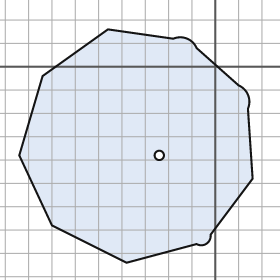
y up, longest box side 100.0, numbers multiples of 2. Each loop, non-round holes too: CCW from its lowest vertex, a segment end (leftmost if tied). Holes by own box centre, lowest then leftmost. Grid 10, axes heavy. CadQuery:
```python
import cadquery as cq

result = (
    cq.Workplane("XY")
    .moveTo(-38.0, -84.0)
    .lineTo(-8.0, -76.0)
    .threePointArc((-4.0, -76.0), (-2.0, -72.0))
    .lineTo(16.0, -48.0)
    .lineTo(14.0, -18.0)
    .threePointArc((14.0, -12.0), (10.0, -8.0))
    .lineTo(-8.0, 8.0)
    .threePointArc((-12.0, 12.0), (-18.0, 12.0))
    .lineTo(-46.0, 16.0)
    .lineTo(-74.0, -4.0)
    .lineTo(-84.0, -38.0)
    .lineTo(-70.0, -68.0)
    .close()
    .moveTo(-24.0, -38.0)
    .circle(2.0)
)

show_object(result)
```